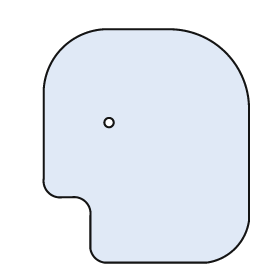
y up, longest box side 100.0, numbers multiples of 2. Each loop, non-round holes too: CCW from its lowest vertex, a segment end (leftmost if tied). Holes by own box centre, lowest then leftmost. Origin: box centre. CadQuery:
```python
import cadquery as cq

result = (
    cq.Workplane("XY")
    .moveTo(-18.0, -50.0)
    .lineTo(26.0, -50.0)
    .threePointArc((38.0, -44.0), (44.0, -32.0))
    .lineTo(44.0, 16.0)
    .threePointArc((34.0, 40.0), (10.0, 50.0))
    .lineTo(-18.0, 50.0)
    .threePointArc((-36.0, 42.0), (-44.0, 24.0))
    .lineTo(-44.0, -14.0)
    .threePointArc((-42.0, -20.0), (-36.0, -22.0))
    .lineTo(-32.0, -22.0)
    .threePointArc((-26.0, -24.0), (-24.0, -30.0))
    .lineTo(-24.0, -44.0)
    .threePointArc((-22.0, -48.0), (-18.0, -50.0))
    .close()
    .moveTo(-16.0, 10.0)
    .circle(2.0)
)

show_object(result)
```